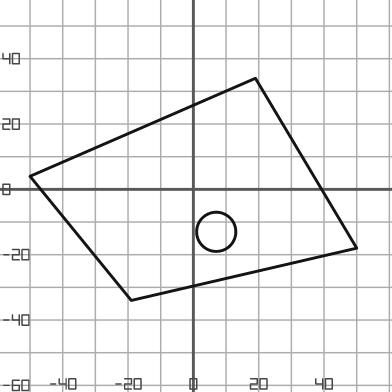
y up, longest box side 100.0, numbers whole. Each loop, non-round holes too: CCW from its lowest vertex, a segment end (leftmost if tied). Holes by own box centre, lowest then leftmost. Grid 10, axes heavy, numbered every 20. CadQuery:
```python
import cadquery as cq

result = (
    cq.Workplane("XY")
    .moveTo(-19.0, -34.0)
    .lineTo(50.0, -18.0)
    .lineTo(19.0, 34.0)
    .lineTo(-50.0, 4.0)
    .close()
    .moveTo(7.0, -13.0)
    .circle(6.0)
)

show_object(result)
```